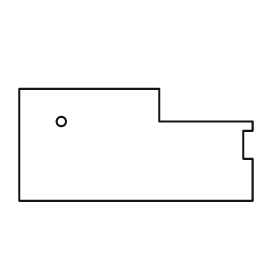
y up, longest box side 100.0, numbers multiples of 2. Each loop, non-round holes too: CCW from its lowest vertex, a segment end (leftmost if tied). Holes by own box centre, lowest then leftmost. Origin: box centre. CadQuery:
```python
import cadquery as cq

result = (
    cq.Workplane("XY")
    .moveTo(-50.0, -24.0)
    .lineTo(50.0, -24.0)
    .lineTo(50.0, -6.0)
    .lineTo(46.0, -6.0)
    .lineTo(46.0, 6.0)
    .lineTo(50.0, 6.0)
    .lineTo(50.0, 10.0)
    .lineTo(10.0, 10.0)
    .lineTo(10.0, 24.0)
    .lineTo(-50.0, 24.0)
    .close()
    .moveTo(-32.0, 10.0)
    .circle(2.0)
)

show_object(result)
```